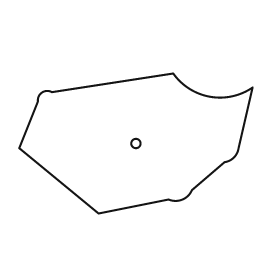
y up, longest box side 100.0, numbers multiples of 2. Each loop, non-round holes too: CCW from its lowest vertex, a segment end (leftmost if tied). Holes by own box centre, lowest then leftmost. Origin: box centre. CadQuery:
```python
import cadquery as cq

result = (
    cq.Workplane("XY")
    .moveTo(-16.0, -30.0)
    .lineTo(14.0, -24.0)
    .threePointArc((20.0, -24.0), (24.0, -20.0))
    .lineTo(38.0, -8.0)
    .threePointArc((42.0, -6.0), (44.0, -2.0))
    .lineTo(50.0, 24.0)
    .threePointArc((32.0, 20.0), (16.0, 30.0))
    .lineTo(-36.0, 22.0)
    .threePointArc((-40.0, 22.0), (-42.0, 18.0))
    .lineTo(-50.0, -2.0)
    .close()
    .moveTo(0.0, 0.0)
    .circle(2.0)
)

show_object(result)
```